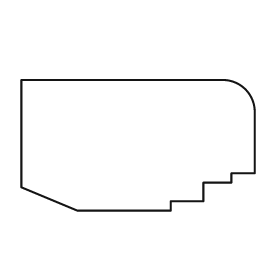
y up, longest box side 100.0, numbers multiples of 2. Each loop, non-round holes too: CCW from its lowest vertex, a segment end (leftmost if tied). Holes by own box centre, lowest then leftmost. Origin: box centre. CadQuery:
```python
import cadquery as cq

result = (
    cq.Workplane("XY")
    .moveTo(-26.0, -28.0)
    .lineTo(14.0, -28.0)
    .lineTo(14.0, -24.0)
    .lineTo(28.0, -24.0)
    .lineTo(28.0, -16.0)
    .lineTo(40.0, -16.0)
    .lineTo(40.0, -12.0)
    .lineTo(50.0, -12.0)
    .lineTo(50.0, 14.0)
    .threePointArc((46.0, 24.0), (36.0, 28.0))
    .lineTo(-50.0, 28.0)
    .lineTo(-50.0, -18.0)
    .close()
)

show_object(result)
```